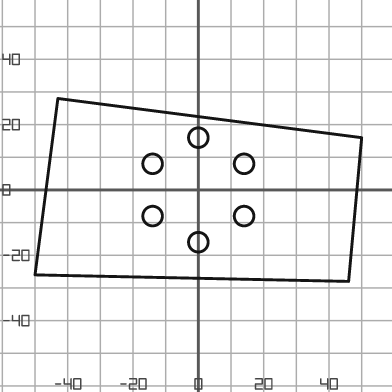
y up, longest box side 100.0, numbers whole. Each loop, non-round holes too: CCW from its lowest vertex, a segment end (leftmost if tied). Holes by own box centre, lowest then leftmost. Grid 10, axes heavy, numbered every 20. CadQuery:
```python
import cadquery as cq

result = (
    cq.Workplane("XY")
    .moveTo(46.0, -28.0)
    .lineTo(50.0, 16.0)
    .lineTo(-43.0, 28.0)
    .lineTo(-50.0, -26.0)
    .close()
    .moveTo(0.0, -16.0)
    .circle(3.0)
    .moveTo(-14.0, -8.0)
    .circle(3.0)
    .moveTo(14.0, -8.0)
    .circle(3.0)
    .moveTo(-14.0, 8.0)
    .circle(3.0)
    .moveTo(14.0, 8.0)
    .circle(3.0)
    .moveTo(0.0, 16.0)
    .circle(3.0)
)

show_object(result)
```